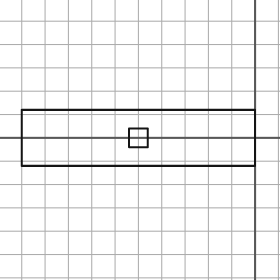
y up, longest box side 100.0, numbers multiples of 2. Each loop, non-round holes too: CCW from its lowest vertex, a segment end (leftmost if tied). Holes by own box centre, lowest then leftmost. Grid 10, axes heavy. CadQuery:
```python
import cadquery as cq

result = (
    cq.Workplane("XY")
    .moveTo(-100.0, -12.0)
    .lineTo(0.0, -12.0)
    .lineTo(0.0, 12.0)
    .lineTo(-100.0, 12.0)
    .close()
    .moveTo(-54.0, -4.0)
    .lineTo(-46.0, -4.0)
    .lineTo(-46.0, 4.0)
    .lineTo(-54.0, 4.0)
    .close()
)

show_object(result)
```